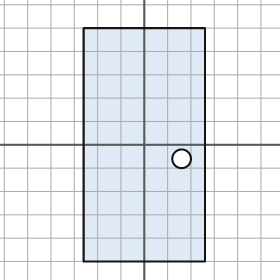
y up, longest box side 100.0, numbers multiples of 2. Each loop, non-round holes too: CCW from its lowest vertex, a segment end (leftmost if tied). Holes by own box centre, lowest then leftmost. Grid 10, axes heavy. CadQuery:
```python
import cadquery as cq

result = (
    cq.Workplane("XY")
    .moveTo(-26.0, -50.0)
    .lineTo(26.0, -50.0)
    .lineTo(26.0, 50.0)
    .lineTo(-26.0, 50.0)
    .close()
    .moveTo(16.0, -6.0)
    .circle(4.0)
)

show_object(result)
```